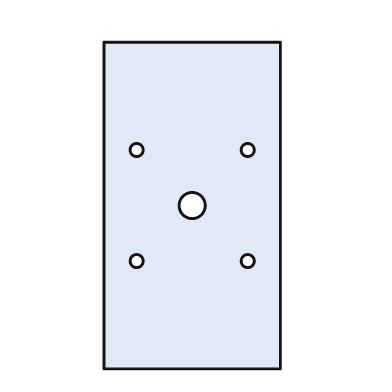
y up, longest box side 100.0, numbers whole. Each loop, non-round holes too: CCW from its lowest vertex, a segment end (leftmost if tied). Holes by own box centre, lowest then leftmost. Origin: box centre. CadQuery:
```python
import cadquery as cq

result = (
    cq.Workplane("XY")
    .moveTo(-27.0, -50.0)
    .lineTo(27.0, -50.0)
    .lineTo(27.0, 50.0)
    .lineTo(-27.0, 50.0)
    .close()
    .moveTo(-17.0, -17.0)
    .circle(2.0)
    .moveTo(17.0, -17.0)
    .circle(2.0)
    .moveTo(0.0, 0.0)
    .circle(4.0)
    .moveTo(-17.0, 17.0)
    .circle(2.0)
    .moveTo(17.0, 17.0)
    .circle(2.0)
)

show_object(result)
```